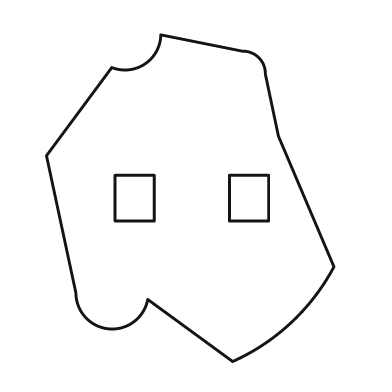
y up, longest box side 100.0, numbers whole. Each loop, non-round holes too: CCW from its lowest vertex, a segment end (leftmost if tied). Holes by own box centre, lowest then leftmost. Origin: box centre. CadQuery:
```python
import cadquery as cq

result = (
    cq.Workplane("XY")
    .moveTo(13.0, -50.0)
    .threePointArc((31.0, -38.0), (44.0, -21.0))
    .lineTo(27.0, 19.0)
    .lineTo(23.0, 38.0)
    .threePointArc((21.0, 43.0), (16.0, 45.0))
    .lineTo(-9.0, 50.0)
    .threePointArc((-14.0, 41.0), (-24.0, 40.0))
    .lineTo(-44.0, 13.0)
    .lineTo(-35.0, -29.0)
    .threePointArc((-25.0, -40.0), (-13.0, -31.0))
    .close()
    .moveTo(-23.0, -7.0)
    .lineTo(-11.0, -7.0)
    .lineTo(-11.0, 7.0)
    .lineTo(-23.0, 7.0)
    .close()
    .moveTo(12.0, -7.0)
    .lineTo(24.0, -7.0)
    .lineTo(24.0, 7.0)
    .lineTo(12.0, 7.0)
    .close()
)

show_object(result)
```